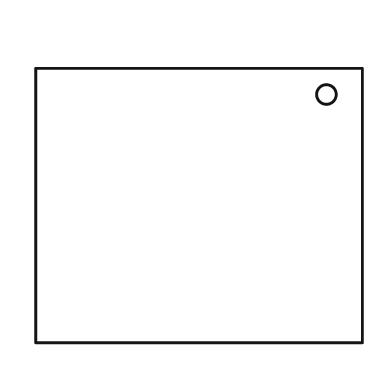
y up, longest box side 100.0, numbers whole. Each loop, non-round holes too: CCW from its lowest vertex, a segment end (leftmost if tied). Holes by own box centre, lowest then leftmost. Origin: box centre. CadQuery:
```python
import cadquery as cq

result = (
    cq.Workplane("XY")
    .moveTo(-50.0, -42.0)
    .lineTo(50.0, -42.0)
    .lineTo(50.0, 42.0)
    .lineTo(-50.0, 42.0)
    .close()
    .moveTo(39.0, 34.0)
    .circle(3.0)
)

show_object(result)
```